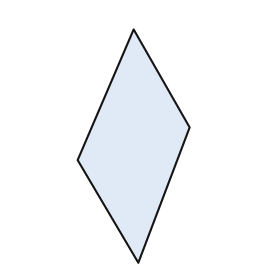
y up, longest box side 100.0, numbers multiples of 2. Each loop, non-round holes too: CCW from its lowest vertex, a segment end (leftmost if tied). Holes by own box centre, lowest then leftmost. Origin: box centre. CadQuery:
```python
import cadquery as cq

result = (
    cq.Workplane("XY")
    .moveTo(2.0, -50.0)
    .lineTo(24.0, 8.0)
    .lineTo(0.0, 50.0)
    .lineTo(-24.0, -6.0)
    .close()
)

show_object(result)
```